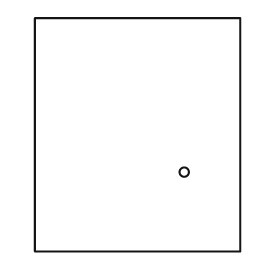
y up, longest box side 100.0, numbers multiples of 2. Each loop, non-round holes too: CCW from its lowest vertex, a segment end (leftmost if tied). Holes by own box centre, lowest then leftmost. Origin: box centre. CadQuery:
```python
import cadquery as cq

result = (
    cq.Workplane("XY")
    .moveTo(-44.0, -50.0)
    .lineTo(44.0, -50.0)
    .lineTo(44.0, 50.0)
    .lineTo(-44.0, 50.0)
    .close()
    .moveTo(20.0, -16.0)
    .circle(2.0)
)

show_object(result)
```